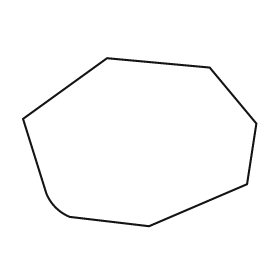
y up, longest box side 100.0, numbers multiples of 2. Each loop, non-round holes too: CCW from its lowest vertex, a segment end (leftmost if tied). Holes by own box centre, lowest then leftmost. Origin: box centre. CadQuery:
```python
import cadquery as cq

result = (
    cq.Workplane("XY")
    .moveTo(4.0, -36.0)
    .lineTo(46.0, -18.0)
    .lineTo(50.0, 8.0)
    .lineTo(30.0, 32.0)
    .lineTo(-14.0, 36.0)
    .lineTo(-50.0, 10.0)
    .lineTo(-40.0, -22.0)
    .threePointArc((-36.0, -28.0), (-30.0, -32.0))
    .close()
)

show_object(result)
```